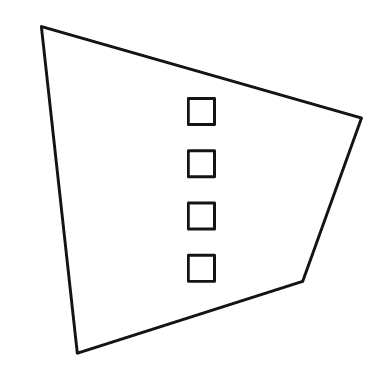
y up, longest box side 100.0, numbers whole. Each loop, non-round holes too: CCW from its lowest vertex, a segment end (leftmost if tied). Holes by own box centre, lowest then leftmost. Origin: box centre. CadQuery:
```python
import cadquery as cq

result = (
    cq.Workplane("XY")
    .moveTo(-38.0, -50.0)
    .lineTo(31.0, -28.0)
    .lineTo(49.0, 22.0)
    .lineTo(-49.0, 50.0)
    .close()
    .moveTo(-4.0, -28.0)
    .lineTo(4.0, -28.0)
    .lineTo(4.0, -20.0)
    .lineTo(-4.0, -20.0)
    .close()
    .moveTo(-4.0, -12.0)
    .lineTo(4.0, -12.0)
    .lineTo(4.0, -4.0)
    .lineTo(-4.0, -4.0)
    .close()
    .moveTo(-4.0, 4.0)
    .lineTo(4.0, 4.0)
    .lineTo(4.0, 12.0)
    .lineTo(-4.0, 12.0)
    .close()
    .moveTo(-4.0, 20.0)
    .lineTo(4.0, 20.0)
    .lineTo(4.0, 28.0)
    .lineTo(-4.0, 28.0)
    .close()
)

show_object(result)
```